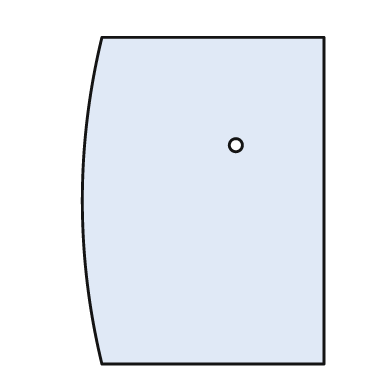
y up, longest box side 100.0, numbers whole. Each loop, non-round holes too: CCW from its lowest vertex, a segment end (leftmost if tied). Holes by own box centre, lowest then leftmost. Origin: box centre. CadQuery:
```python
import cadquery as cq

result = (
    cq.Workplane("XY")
    .moveTo(-31.0, -50.0)
    .lineTo(37.0, -50.0)
    .lineTo(37.0, 50.0)
    .lineTo(-31.0, 50.0)
    .threePointArc((-37.0, 0.0), (-31.0, -50.0))
    .close()
    .moveTo(10.0, 17.0)
    .circle(2.0)
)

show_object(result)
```